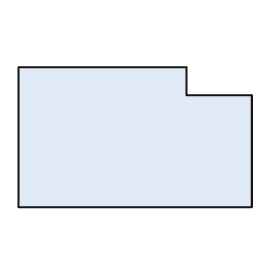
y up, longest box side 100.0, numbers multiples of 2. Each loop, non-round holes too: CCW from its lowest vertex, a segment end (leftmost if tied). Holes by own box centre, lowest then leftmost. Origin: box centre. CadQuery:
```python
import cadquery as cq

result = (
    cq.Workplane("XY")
    .moveTo(-50.0, -30.0)
    .lineTo(50.0, -30.0)
    .lineTo(50.0, 18.0)
    .lineTo(22.0, 18.0)
    .lineTo(22.0, 30.0)
    .lineTo(-50.0, 30.0)
    .close()
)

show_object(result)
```